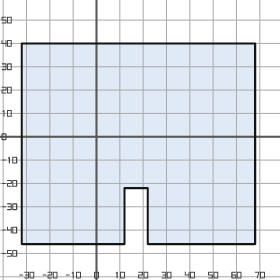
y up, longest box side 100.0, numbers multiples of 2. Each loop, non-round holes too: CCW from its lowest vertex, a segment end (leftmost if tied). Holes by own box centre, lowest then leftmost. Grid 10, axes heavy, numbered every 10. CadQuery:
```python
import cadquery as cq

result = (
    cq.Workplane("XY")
    .moveTo(-32.0, -46.0)
    .lineTo(12.0, -46.0)
    .lineTo(12.0, -22.0)
    .lineTo(22.0, -22.0)
    .lineTo(22.0, -46.0)
    .lineTo(68.0, -46.0)
    .lineTo(68.0, 40.0)
    .lineTo(-32.0, 40.0)
    .close()
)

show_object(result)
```